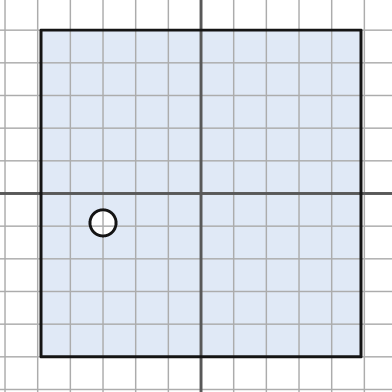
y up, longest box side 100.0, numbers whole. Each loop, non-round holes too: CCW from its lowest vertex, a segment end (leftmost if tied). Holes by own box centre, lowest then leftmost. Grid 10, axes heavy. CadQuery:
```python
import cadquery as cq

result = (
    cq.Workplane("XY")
    .moveTo(-49.0, -50.0)
    .lineTo(49.0, -50.0)
    .lineTo(49.0, 50.0)
    .lineTo(-49.0, 50.0)
    .close()
    .moveTo(-30.0, -9.0)
    .circle(4.0)
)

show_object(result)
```